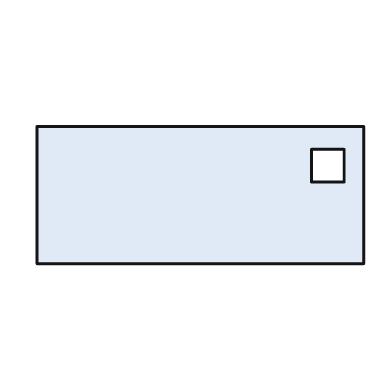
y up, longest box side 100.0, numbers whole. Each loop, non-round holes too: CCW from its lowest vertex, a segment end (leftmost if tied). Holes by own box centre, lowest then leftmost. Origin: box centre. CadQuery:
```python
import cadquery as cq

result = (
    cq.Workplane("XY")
    .moveTo(-50.0, -21.0)
    .lineTo(50.0, -21.0)
    .lineTo(50.0, 21.0)
    .lineTo(-50.0, 21.0)
    .close()
    .moveTo(34.0, 4.0)
    .lineTo(44.0, 4.0)
    .lineTo(44.0, 14.0)
    .lineTo(34.0, 14.0)
    .close()
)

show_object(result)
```